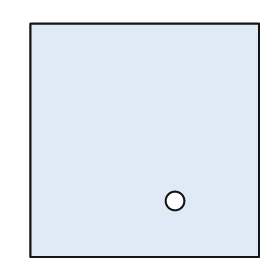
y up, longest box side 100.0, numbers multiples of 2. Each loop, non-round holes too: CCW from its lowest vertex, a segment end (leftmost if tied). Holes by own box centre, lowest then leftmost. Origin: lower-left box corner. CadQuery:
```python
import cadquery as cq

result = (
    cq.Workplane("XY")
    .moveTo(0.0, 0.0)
    .lineTo(98.0, 0.0)
    .lineTo(98.0, 100.0)
    .lineTo(0.0, 100.0)
    .close()
    .moveTo(62.0, 24.0)
    .circle(4.0)
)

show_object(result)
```